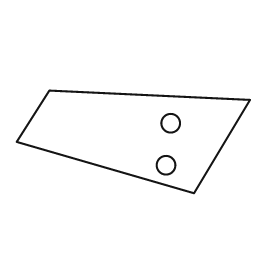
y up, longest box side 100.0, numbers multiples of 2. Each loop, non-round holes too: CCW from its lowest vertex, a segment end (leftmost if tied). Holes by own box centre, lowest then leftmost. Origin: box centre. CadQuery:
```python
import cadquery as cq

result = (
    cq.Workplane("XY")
    .moveTo(26.0, -22.0)
    .lineTo(50.0, 18.0)
    .lineTo(-36.0, 22.0)
    .lineTo(-50.0, 0.0)
    .close()
    .moveTo(14.0, -10.0)
    .circle(4.0)
    .moveTo(16.0, 8.0)
    .circle(4.0)
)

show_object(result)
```